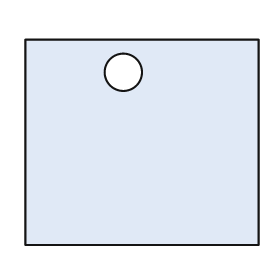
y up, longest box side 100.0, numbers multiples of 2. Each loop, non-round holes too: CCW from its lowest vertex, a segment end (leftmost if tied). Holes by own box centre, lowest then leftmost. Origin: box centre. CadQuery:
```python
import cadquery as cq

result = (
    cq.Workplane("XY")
    .moveTo(-50.0, -44.0)
    .lineTo(50.0, -44.0)
    .lineTo(50.0, 44.0)
    .lineTo(-50.0, 44.0)
    .close()
    .moveTo(-8.0, 30.0)
    .circle(8.0)
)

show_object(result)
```